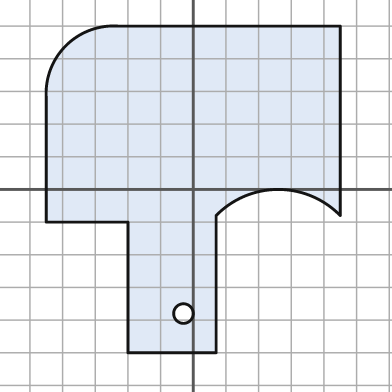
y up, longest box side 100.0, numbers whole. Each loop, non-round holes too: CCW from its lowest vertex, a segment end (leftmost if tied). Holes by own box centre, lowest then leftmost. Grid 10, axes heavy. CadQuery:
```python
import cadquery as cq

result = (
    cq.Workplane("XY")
    .moveTo(-20.0, -50.0)
    .lineTo(7.0, -50.0)
    .lineTo(7.0, -8.0)
    .threePointArc((26.0, 0.0), (45.0, -8.0))
    .lineTo(45.0, 50.0)
    .lineTo(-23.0, 50.0)
    .threePointArc((-39.0, 44.0), (-45.0, 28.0))
    .lineTo(-45.0, -10.0)
    .lineTo(-20.0, -10.0)
    .close()
    .moveTo(-3.0, -38.0)
    .circle(3.0)
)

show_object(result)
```